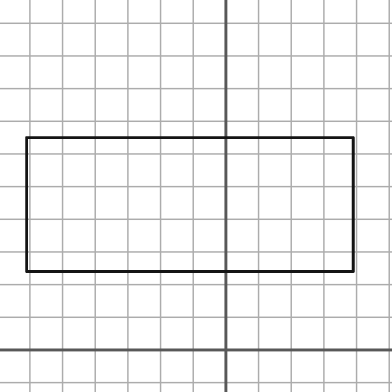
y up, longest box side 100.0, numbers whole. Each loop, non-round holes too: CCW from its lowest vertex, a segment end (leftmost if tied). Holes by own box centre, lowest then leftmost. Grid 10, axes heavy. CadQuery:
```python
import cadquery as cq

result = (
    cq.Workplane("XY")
    .moveTo(-61.0, 24.0)
    .lineTo(39.0, 24.0)
    .lineTo(39.0, 65.0)
    .lineTo(-61.0, 65.0)
    .close()
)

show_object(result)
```